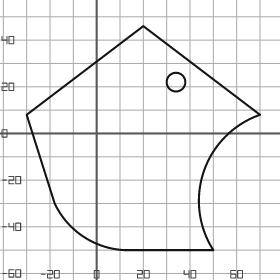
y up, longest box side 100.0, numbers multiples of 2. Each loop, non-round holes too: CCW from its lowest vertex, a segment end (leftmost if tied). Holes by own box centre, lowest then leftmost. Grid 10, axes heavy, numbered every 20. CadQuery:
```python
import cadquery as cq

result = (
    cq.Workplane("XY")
    .moveTo(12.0, -50.0)
    .lineTo(50.0, -50.0)
    .threePointArc((46.0, -16.0), (70.0, 8.0))
    .lineTo(20.0, 46.0)
    .lineTo(-30.0, 8.0)
    .lineTo(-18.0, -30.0)
    .threePointArc((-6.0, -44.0), (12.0, -50.0))
    .close()
    .moveTo(34.0, 22.0)
    .circle(4.0)
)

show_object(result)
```